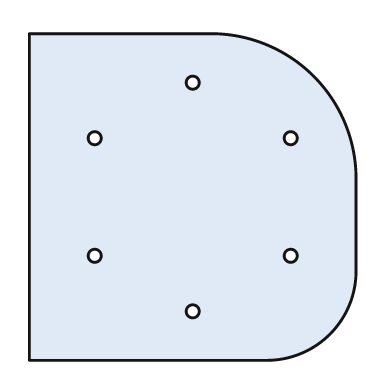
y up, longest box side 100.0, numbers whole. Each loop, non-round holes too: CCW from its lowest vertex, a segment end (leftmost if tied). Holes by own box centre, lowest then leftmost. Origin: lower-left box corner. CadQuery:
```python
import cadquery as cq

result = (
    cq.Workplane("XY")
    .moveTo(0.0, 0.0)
    .lineTo(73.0, 0.0)
    .threePointArc((92.0, 8.0), (100.0, 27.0))
    .lineTo(100.0, 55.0)
    .threePointArc((87.0, 87.0), (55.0, 100.0))
    .lineTo(0.0, 100.0)
    .close()
    .moveTo(50.0, 15.0)
    .circle(2.0)
    .moveTo(20.0, 32.0)
    .circle(2.0)
    .moveTo(80.0, 32.0)
    .circle(2.0)
    .moveTo(20.0, 68.0)
    .circle(2.0)
    .moveTo(80.0, 68.0)
    .circle(2.0)
    .moveTo(50.0, 85.0)
    .circle(2.0)
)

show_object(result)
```